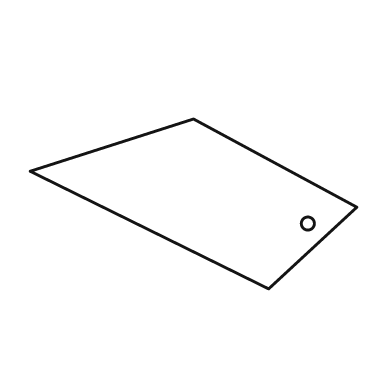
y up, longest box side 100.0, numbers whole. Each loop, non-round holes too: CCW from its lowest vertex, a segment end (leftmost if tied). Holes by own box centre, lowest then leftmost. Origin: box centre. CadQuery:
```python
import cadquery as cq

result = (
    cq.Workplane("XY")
    .moveTo(23.0, -26.0)
    .lineTo(50.0, -1.0)
    .lineTo(0.0, 26.0)
    .lineTo(-50.0, 10.0)
    .close()
    .moveTo(35.0, -6.0)
    .circle(2.0)
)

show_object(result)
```